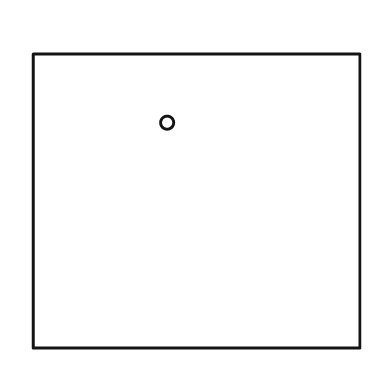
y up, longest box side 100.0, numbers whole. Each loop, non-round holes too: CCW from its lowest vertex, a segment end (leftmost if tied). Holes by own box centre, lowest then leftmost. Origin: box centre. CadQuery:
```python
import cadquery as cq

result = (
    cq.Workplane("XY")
    .moveTo(-50.0, -45.0)
    .lineTo(50.0, -45.0)
    .lineTo(50.0, 45.0)
    .lineTo(-50.0, 45.0)
    .close()
    .moveTo(-9.0, 24.0)
    .circle(2.0)
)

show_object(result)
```